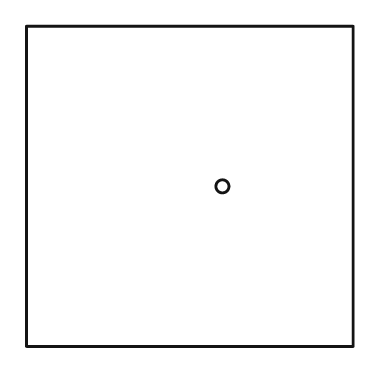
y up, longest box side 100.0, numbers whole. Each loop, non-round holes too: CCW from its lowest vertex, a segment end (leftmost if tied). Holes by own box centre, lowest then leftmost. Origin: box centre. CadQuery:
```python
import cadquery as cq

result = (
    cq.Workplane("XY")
    .moveTo(-50.0, -49.0)
    .lineTo(50.0, -49.0)
    .lineTo(50.0, 49.0)
    .lineTo(-50.0, 49.0)
    .close()
    .moveTo(10.0, 0.0)
    .circle(2.0)
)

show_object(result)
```